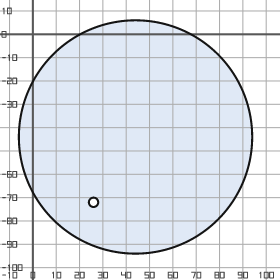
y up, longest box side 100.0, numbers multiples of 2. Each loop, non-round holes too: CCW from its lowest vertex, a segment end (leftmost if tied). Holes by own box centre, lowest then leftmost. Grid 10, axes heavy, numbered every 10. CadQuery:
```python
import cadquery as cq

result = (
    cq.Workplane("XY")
    .moveTo(44.0, -44.0)
    .circle(50.0)
    .moveTo(26.0, -72.0)
    .circle(2.0)
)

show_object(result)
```